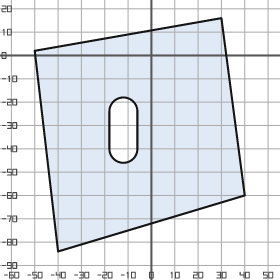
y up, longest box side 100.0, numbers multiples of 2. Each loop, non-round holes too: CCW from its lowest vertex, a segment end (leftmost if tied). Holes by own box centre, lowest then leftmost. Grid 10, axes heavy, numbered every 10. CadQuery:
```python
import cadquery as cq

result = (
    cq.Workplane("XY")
    .moveTo(-40.0, -84.0)
    .lineTo(40.0, -60.0)
    .lineTo(30.0, 16.0)
    .lineTo(-50.0, 2.0)
    .close()
    .moveTo(-18.0, -40.0)
    .threePointArc((-12.0, -46.0), (-6.0, -40.0))
    .lineTo(-6.0, -24.0)
    .threePointArc((-12.0, -18.0), (-18.0, -24.0))
    .close()
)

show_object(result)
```